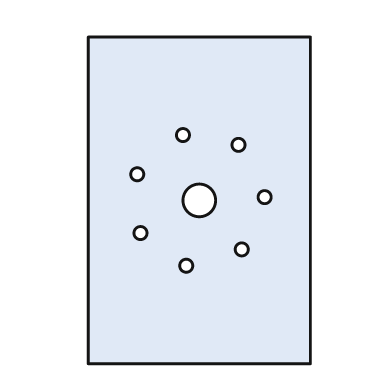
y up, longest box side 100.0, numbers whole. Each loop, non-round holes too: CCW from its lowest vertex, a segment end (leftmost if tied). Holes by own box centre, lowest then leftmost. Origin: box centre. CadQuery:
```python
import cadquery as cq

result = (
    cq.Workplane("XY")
    .moveTo(-34.0, -50.0)
    .lineTo(34.0, -50.0)
    .lineTo(34.0, 50.0)
    .lineTo(-34.0, 50.0)
    .close()
    .moveTo(-4.0, -20.0)
    .circle(2.0)
    .moveTo(13.0, -15.0)
    .circle(2.0)
    .moveTo(-18.0, -10.0)
    .circle(2.0)
    .moveTo(0.0, 0.0)
    .circle(5.0)
    .moveTo(20.0, 1.0)
    .circle(2.0)
    .moveTo(-19.0, 8.0)
    .circle(2.0)
    .moveTo(12.0, 17.0)
    .circle(2.0)
    .moveTo(-5.0, 20.0)
    .circle(2.0)
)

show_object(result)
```